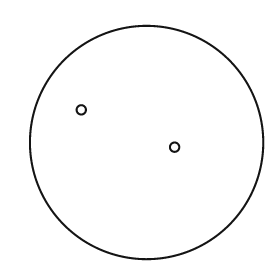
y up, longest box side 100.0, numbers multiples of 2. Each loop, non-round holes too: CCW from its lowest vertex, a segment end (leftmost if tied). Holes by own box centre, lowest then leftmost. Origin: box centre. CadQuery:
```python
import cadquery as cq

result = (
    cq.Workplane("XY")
    .moveTo(0.0, 0.0)
    .circle(50.0)
    .moveTo(12.0, -2.0)
    .circle(2.0)
    .moveTo(-28.0, 14.0)
    .circle(2.0)
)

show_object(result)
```